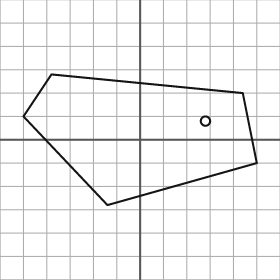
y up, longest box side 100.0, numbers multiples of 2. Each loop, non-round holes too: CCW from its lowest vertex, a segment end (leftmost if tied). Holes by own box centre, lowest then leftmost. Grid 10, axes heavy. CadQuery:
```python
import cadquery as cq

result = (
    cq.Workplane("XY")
    .moveTo(-14.0, -28.0)
    .lineTo(50.0, -10.0)
    .lineTo(44.0, 20.0)
    .lineTo(-38.0, 28.0)
    .lineTo(-50.0, 10.0)
    .close()
    .moveTo(28.0, 8.0)
    .circle(2.0)
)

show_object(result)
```